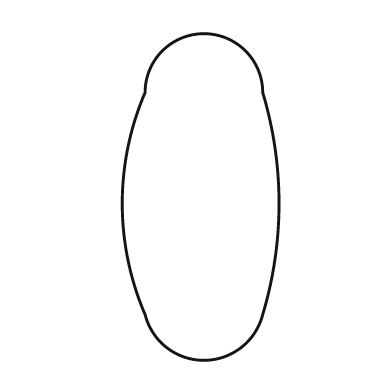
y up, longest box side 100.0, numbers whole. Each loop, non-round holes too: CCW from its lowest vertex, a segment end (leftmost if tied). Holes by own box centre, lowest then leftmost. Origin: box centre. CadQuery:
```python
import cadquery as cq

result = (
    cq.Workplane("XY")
    .moveTo(-17.0, -36.0)
    .threePointArc((1.0, -50.0), (19.0, -36.0))
    .threePointArc((24.0, -2.0), (19.0, 32.0))
    .threePointArc((1.0, 50.0), (-17.0, 32.0))
    .threePointArc((-24.0, -2.0), (-17.0, -36.0))
    .close()
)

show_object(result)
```